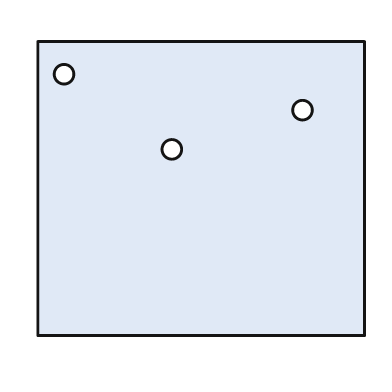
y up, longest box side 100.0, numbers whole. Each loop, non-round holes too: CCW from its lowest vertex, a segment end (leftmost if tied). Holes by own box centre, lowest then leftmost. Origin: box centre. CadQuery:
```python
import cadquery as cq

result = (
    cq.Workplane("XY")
    .moveTo(-50.0, -45.0)
    .lineTo(50.0, -45.0)
    .lineTo(50.0, 45.0)
    .lineTo(-50.0, 45.0)
    .close()
    .moveTo(-9.0, 12.0)
    .circle(3.0)
    .moveTo(31.0, 24.0)
    .circle(3.0)
    .moveTo(-42.0, 35.0)
    .circle(3.0)
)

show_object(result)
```